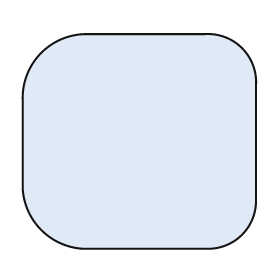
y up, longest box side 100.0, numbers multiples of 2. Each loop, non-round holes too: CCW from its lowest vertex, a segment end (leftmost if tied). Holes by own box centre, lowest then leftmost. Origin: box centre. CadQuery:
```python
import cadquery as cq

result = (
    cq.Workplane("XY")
    .moveTo(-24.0, -46.0)
    .lineTo(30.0, -46.0)
    .threePointArc((44.0, -40.0), (50.0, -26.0))
    .lineTo(50.0, 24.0)
    .threePointArc((44.0, 40.0), (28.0, 46.0))
    .lineTo(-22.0, 46.0)
    .threePointArc((-42.0, 38.0), (-50.0, 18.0))
    .lineTo(-50.0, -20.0)
    .threePointArc((-42.0, -38.0), (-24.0, -46.0))
    .close()
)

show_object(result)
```